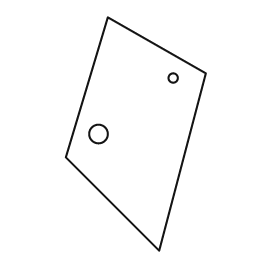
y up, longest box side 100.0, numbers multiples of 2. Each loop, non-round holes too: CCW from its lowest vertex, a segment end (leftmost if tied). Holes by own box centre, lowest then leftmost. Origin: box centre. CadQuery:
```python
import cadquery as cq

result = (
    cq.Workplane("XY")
    .moveTo(10.0, -50.0)
    .lineTo(30.0, 26.0)
    .lineTo(-12.0, 50.0)
    .lineTo(-30.0, -10.0)
    .close()
    .moveTo(-16.0, 0.0)
    .circle(4.0)
    .moveTo(16.0, 24.0)
    .circle(2.0)
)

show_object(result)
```